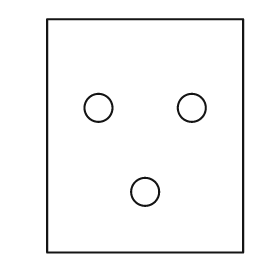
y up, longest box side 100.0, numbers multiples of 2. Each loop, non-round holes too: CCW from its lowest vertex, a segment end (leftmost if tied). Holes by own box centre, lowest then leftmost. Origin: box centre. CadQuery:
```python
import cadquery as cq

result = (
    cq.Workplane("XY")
    .moveTo(-42.0, -50.0)
    .lineTo(42.0, -50.0)
    .lineTo(42.0, 50.0)
    .lineTo(-42.0, 50.0)
    .close()
    .moveTo(0.0, -24.0)
    .circle(6.0)
    .moveTo(-20.0, 12.0)
    .circle(6.0)
    .moveTo(20.0, 12.0)
    .circle(6.0)
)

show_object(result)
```